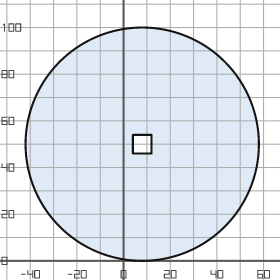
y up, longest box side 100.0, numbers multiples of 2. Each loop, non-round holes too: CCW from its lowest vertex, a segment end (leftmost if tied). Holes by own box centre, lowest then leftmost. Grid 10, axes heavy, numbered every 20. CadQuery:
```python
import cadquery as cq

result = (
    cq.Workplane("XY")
    .moveTo(8.0, 50.0)
    .circle(50.0)
    .moveTo(4.0, 46.0)
    .lineTo(12.0, 46.0)
    .lineTo(12.0, 54.0)
    .lineTo(4.0, 54.0)
    .close()
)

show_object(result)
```